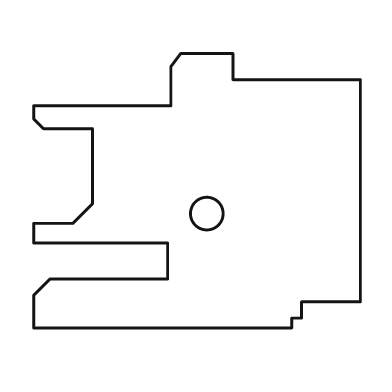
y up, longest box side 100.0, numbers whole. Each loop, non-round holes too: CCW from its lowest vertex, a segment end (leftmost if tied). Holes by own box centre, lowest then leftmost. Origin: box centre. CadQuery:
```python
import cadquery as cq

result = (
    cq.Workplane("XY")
    .moveTo(-50.0, -42.0)
    .lineTo(29.0, -42.0)
    .lineTo(29.0, -39.0)
    .lineTo(32.0, -39.0)
    .lineTo(32.0, -34.0)
    .lineTo(50.0, -34.0)
    .lineTo(50.0, 34.0)
    .lineTo(11.0, 34.0)
    .lineTo(11.0, 42.0)
    .lineTo(-5.0, 42.0)
    .lineTo(-8.0, 38.0)
    .lineTo(-8.0, 26.0)
    .lineTo(-50.0, 26.0)
    .lineTo(-50.0, 22.0)
    .lineTo(-47.0, 19.0)
    .lineTo(-32.0, 19.0)
    .lineTo(-32.0, -4.0)
    .lineTo(-38.0, -10.0)
    .lineTo(-50.0, -10.0)
    .lineTo(-50.0, -16.0)
    .lineTo(-9.0, -16.0)
    .lineTo(-9.0, -27.0)
    .lineTo(-45.0, -27.0)
    .lineTo(-50.0, -32.0)
    .close()
    .moveTo(3.0, -7.0)
    .circle(5.0)
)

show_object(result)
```